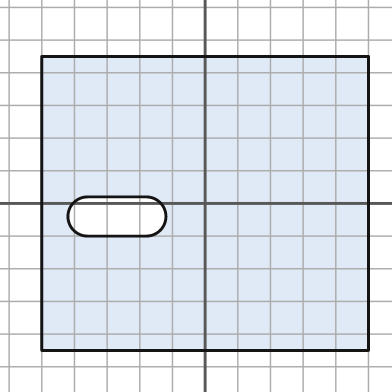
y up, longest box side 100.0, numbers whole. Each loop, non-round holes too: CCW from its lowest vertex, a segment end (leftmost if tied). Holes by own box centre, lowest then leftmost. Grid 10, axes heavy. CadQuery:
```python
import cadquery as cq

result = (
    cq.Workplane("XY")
    .moveTo(-50.0, -45.0)
    .lineTo(50.0, -45.0)
    .lineTo(50.0, 45.0)
    .lineTo(-50.0, 45.0)
    .close()
    .moveTo(-36.0, -10.0)
    .lineTo(-18.0, -10.0)
    .threePointArc((-12.0, -4.0), (-18.0, 2.0))
    .lineTo(-36.0, 2.0)
    .threePointArc((-42.0, -4.0), (-36.0, -10.0))
    .close()
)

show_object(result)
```